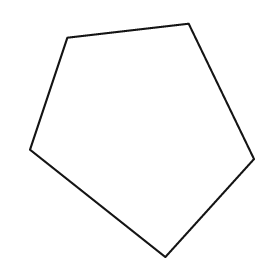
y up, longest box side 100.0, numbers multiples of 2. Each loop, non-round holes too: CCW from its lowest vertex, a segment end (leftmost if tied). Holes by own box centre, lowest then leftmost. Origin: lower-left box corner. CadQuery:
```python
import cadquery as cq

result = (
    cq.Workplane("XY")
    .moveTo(58.0, 0.0)
    .lineTo(96.0, 42.0)
    .lineTo(68.0, 100.0)
    .lineTo(16.0, 94.0)
    .lineTo(0.0, 46.0)
    .close()
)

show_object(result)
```